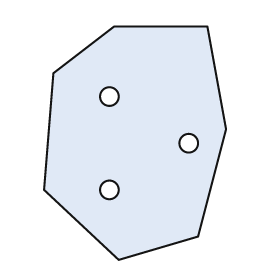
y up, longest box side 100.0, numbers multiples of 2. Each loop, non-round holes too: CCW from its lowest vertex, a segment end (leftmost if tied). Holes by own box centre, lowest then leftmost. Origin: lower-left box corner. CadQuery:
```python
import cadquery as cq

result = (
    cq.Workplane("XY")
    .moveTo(32.0, 0.0)
    .lineTo(66.0, 10.0)
    .lineTo(78.0, 56.0)
    .lineTo(70.0, 100.0)
    .lineTo(30.0, 100.0)
    .lineTo(4.0, 80.0)
    .lineTo(0.0, 30.0)
    .close()
    .moveTo(28.0, 30.0)
    .circle(4.0)
    .moveTo(62.0, 50.0)
    .circle(4.0)
    .moveTo(28.0, 70.0)
    .circle(4.0)
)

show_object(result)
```